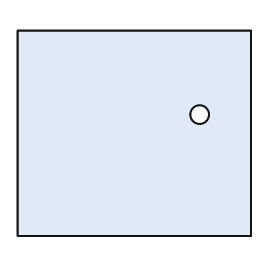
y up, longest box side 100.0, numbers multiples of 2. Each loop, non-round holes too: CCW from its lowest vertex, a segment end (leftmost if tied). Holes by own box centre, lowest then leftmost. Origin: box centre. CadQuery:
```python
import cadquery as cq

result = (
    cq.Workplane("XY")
    .moveTo(-50.0, -44.0)
    .lineTo(50.0, -44.0)
    .lineTo(50.0, 44.0)
    .lineTo(-50.0, 44.0)
    .close()
    .moveTo(28.0, 8.0)
    .circle(4.0)
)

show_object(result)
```